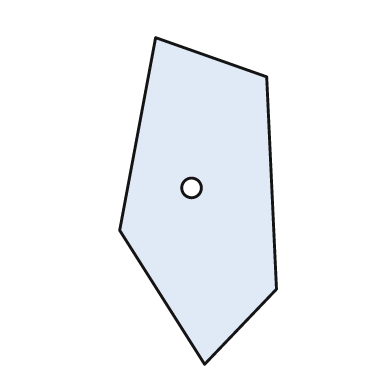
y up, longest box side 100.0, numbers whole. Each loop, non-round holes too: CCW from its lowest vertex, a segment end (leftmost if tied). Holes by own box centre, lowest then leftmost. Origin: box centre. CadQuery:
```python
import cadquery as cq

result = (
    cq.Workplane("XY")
    .moveTo(2.0, -50.0)
    .lineTo(24.0, -27.0)
    .lineTo(21.0, 38.0)
    .lineTo(-13.0, 50.0)
    .lineTo(-24.0, -9.0)
    .close()
    .moveTo(-2.0, 4.0)
    .circle(3.0)
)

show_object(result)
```